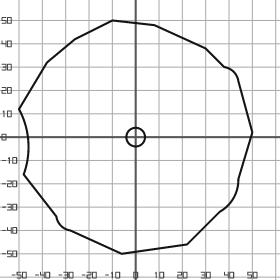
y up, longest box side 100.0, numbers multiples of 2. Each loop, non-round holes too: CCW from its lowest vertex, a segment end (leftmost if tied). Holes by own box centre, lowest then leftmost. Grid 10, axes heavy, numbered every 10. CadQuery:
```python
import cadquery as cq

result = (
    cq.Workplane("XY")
    .moveTo(-6.0, -50.0)
    .lineTo(22.0, -46.0)
    .lineTo(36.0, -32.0)
    .threePointArc((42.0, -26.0), (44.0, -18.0))
    .lineTo(50.0, 2.0)
    .lineTo(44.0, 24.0)
    .threePointArc((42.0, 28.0), (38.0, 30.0))
    .lineTo(30.0, 38.0)
    .lineTo(8.0, 48.0)
    .lineTo(-10.0, 50.0)
    .lineTo(-26.0, 42.0)
    .lineTo(-38.0, 32.0)
    .lineTo(-50.0, 12.0)
    .threePointArc((-46.0, -2.0), (-48.0, -16.0))
    .lineTo(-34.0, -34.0)
    .threePointArc((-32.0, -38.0), (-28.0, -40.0))
    .close()
    .moveTo(0.0, 0.0)
    .circle(4.0)
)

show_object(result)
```